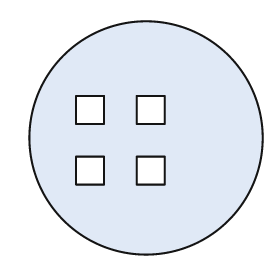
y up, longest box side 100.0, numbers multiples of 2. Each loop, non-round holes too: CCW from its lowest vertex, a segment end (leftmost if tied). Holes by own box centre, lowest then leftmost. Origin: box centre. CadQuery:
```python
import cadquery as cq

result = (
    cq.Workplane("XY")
    .moveTo(0.0, 0.0)
    .circle(50.0)
    .moveTo(-30.0, -20.0)
    .lineTo(-18.0, -20.0)
    .lineTo(-18.0, -8.0)
    .lineTo(-30.0, -8.0)
    .close()
    .moveTo(-4.0, -20.0)
    .lineTo(8.0, -20.0)
    .lineTo(8.0, -8.0)
    .lineTo(-4.0, -8.0)
    .close()
    .moveTo(-30.0, 6.0)
    .lineTo(-18.0, 6.0)
    .lineTo(-18.0, 18.0)
    .lineTo(-30.0, 18.0)
    .close()
    .moveTo(-4.0, 6.0)
    .lineTo(8.0, 6.0)
    .lineTo(8.0, 18.0)
    .lineTo(-4.0, 18.0)
    .close()
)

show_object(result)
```